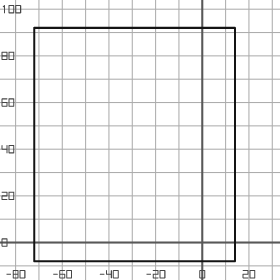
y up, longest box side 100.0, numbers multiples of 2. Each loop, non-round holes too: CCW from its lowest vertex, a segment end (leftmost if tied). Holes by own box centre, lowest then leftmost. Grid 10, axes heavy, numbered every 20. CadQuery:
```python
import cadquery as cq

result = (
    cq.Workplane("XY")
    .moveTo(-72.0, -8.0)
    .lineTo(14.0, -8.0)
    .lineTo(14.0, 92.0)
    .lineTo(-72.0, 92.0)
    .close()
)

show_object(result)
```